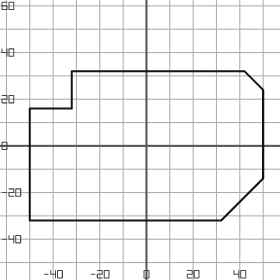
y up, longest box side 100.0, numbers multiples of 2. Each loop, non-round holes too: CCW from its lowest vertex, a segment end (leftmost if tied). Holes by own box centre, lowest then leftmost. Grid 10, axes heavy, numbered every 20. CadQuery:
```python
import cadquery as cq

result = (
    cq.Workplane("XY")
    .moveTo(-50.0, -32.0)
    .lineTo(32.0, -32.0)
    .lineTo(50.0, -14.0)
    .lineTo(50.0, 24.0)
    .lineTo(42.0, 32.0)
    .lineTo(-32.0, 32.0)
    .lineTo(-32.0, 16.0)
    .lineTo(-50.0, 16.0)
    .close()
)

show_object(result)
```